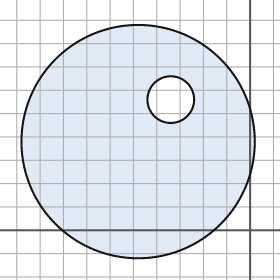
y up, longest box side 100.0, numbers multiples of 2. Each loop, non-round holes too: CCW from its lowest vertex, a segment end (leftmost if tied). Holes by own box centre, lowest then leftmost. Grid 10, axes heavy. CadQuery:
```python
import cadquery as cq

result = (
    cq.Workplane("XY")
    .moveTo(-48.0, 38.0)
    .circle(50.0)
    .moveTo(-34.0, 56.0)
    .circle(10.0)
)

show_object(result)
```